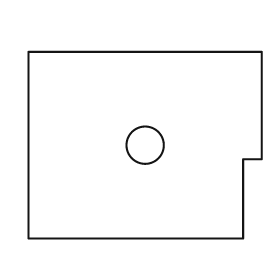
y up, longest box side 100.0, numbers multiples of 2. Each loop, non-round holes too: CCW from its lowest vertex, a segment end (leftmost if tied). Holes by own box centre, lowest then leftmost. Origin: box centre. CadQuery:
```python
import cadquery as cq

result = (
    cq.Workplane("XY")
    .moveTo(-50.0, -40.0)
    .lineTo(42.0, -40.0)
    .lineTo(42.0, -6.0)
    .lineTo(50.0, -6.0)
    .lineTo(50.0, 40.0)
    .lineTo(-50.0, 40.0)
    .close()
    .moveTo(0.0, 0.0)
    .circle(8.0)
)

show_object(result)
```